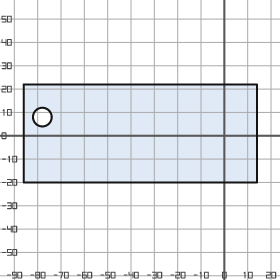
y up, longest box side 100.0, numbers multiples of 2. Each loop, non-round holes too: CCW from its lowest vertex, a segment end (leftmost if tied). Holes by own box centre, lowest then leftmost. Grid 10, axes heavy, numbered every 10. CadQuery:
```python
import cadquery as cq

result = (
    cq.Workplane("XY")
    .moveTo(-86.0, -20.0)
    .lineTo(14.0, -20.0)
    .lineTo(14.0, 22.0)
    .lineTo(-86.0, 22.0)
    .close()
    .moveTo(-78.0, 8.0)
    .circle(4.0)
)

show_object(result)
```